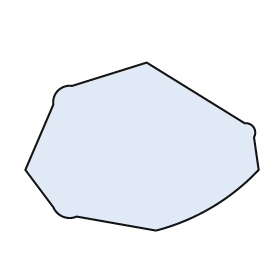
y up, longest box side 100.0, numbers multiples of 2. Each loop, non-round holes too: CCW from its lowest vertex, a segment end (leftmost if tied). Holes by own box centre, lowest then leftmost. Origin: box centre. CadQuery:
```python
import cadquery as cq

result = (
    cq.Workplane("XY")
    .moveTo(6.0, -36.0)
    .threePointArc((30.0, -26.0), (50.0, -10.0))
    .lineTo(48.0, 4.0)
    .threePointArc((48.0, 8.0), (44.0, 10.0))
    .lineTo(2.0, 36.0)
    .lineTo(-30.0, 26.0)
    .threePointArc((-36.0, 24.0), (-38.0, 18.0))
    .lineTo(-50.0, -10.0)
    .lineTo(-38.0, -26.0)
    .threePointArc((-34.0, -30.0), (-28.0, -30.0))
    .close()
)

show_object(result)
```